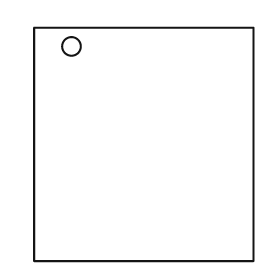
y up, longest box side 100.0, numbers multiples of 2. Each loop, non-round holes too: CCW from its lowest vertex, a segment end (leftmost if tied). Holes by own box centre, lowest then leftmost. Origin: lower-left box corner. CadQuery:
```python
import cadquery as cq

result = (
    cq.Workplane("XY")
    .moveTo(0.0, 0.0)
    .lineTo(94.0, 0.0)
    .lineTo(94.0, 100.0)
    .lineTo(0.0, 100.0)
    .close()
    .moveTo(16.0, 92.0)
    .circle(4.0)
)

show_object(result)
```